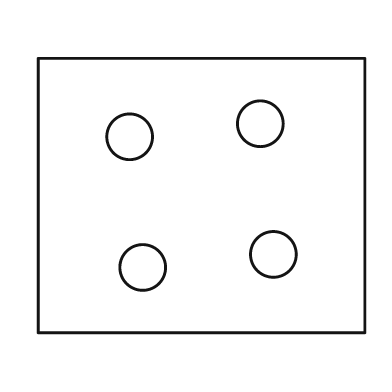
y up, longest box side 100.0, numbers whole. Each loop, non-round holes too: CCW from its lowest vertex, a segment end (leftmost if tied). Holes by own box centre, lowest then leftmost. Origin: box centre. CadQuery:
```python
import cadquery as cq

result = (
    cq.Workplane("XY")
    .moveTo(-50.0, -42.0)
    .lineTo(50.0, -42.0)
    .lineTo(50.0, 42.0)
    .lineTo(-50.0, 42.0)
    .close()
    .moveTo(-18.0, -22.0)
    .circle(7.0)
    .moveTo(22.0, -18.0)
    .circle(7.0)
    .moveTo(-22.0, 18.0)
    .circle(7.0)
    .moveTo(18.0, 22.0)
    .circle(7.0)
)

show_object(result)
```